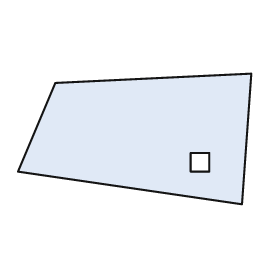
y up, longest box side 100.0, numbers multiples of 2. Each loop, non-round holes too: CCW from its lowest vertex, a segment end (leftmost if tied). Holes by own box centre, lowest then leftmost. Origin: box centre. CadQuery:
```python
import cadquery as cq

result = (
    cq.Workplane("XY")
    .moveTo(46.0, -28.0)
    .lineTo(50.0, 28.0)
    .lineTo(-34.0, 24.0)
    .lineTo(-50.0, -14.0)
    .close()
    .moveTo(24.0, -14.0)
    .lineTo(32.0, -14.0)
    .lineTo(32.0, -6.0)
    .lineTo(24.0, -6.0)
    .close()
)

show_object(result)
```